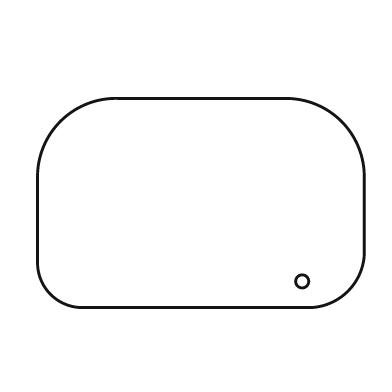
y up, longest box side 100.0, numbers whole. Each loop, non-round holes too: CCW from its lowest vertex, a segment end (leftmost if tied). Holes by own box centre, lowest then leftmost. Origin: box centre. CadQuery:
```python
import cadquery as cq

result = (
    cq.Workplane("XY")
    .moveTo(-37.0, -32.0)
    .lineTo(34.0, -32.0)
    .threePointArc((45.0, -27.0), (50.0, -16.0))
    .lineTo(50.0, 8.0)
    .threePointArc((43.0, 25.0), (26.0, 32.0))
    .lineTo(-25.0, 32.0)
    .threePointArc((-43.0, 25.0), (-50.0, 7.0))
    .lineTo(-50.0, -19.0)
    .threePointArc((-46.0, -28.0), (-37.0, -32.0))
    .close()
    .moveTo(31.0, -24.0)
    .circle(2.0)
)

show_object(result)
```